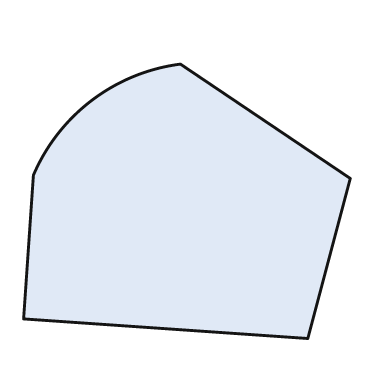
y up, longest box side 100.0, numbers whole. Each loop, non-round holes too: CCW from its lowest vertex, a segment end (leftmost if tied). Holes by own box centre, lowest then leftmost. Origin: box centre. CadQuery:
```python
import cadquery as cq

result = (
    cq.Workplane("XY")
    .moveTo(37.0, -42.0)
    .lineTo(50.0, 7.0)
    .lineTo(-2.0, 42.0)
    .threePointArc((-29.0, 31.0), (-47.0, 8.0))
    .lineTo(-50.0, -36.0)
    .close()
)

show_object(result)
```